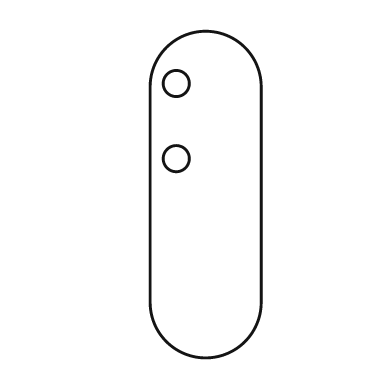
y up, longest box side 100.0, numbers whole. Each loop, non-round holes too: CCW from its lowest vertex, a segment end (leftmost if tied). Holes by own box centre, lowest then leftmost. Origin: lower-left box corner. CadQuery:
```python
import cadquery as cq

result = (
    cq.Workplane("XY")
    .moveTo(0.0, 17.0)
    .threePointArc((17.0, 0.0), (34.0, 17.0))
    .lineTo(34.0, 83.0)
    .threePointArc((17.0, 100.0), (0.0, 83.0))
    .close()
    .moveTo(8.0, 61.0)
    .circle(4.0)
    .moveTo(8.0, 84.0)
    .circle(4.0)
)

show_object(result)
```